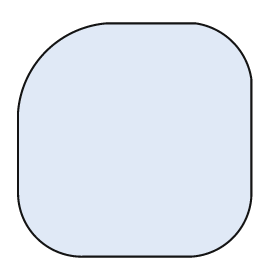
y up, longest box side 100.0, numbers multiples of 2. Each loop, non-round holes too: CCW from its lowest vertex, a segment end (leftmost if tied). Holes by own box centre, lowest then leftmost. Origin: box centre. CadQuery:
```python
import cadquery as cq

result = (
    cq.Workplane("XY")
    .moveTo(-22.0, -50.0)
    .lineTo(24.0, -50.0)
    .threePointArc((42.0, -42.0), (50.0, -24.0))
    .lineTo(50.0, 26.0)
    .threePointArc((42.0, 42.0), (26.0, 50.0))
    .lineTo(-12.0, 50.0)
    .threePointArc((-38.0, 38.0), (-50.0, 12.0))
    .lineTo(-50.0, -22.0)
    .threePointArc((-42.0, -42.0), (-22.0, -50.0))
    .close()
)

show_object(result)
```